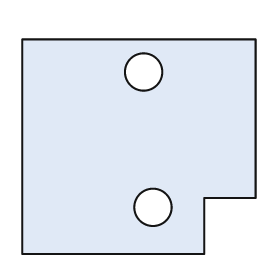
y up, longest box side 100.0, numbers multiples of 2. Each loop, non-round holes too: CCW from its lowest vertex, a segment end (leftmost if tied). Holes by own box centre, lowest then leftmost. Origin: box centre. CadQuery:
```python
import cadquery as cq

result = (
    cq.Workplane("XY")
    .moveTo(-50.0, -46.0)
    .lineTo(28.0, -46.0)
    .lineTo(28.0, -22.0)
    .lineTo(50.0, -22.0)
    .lineTo(50.0, 46.0)
    .lineTo(-50.0, 46.0)
    .close()
    .moveTo(6.0, -26.0)
    .circle(8.0)
    .moveTo(2.0, 32.0)
    .circle(8.0)
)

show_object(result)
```